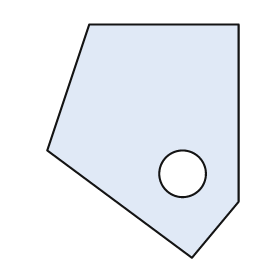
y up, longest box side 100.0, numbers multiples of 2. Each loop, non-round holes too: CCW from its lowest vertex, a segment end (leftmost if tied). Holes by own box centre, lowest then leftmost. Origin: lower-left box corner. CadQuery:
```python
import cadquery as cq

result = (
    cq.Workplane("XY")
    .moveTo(62.0, 0.0)
    .lineTo(82.0, 24.0)
    .lineTo(82.0, 100.0)
    .lineTo(18.0, 100.0)
    .lineTo(0.0, 46.0)
    .close()
    .moveTo(58.0, 36.0)
    .circle(10.0)
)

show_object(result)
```